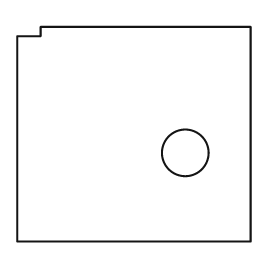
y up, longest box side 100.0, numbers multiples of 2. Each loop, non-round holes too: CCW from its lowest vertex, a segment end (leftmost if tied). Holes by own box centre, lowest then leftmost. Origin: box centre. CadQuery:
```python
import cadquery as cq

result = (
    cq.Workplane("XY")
    .moveTo(-50.0, -46.0)
    .lineTo(50.0, -46.0)
    .lineTo(50.0, 46.0)
    .lineTo(-40.0, 46.0)
    .lineTo(-40.0, 42.0)
    .lineTo(-50.0, 42.0)
    .close()
    .moveTo(22.0, -8.0)
    .circle(10.0)
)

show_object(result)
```